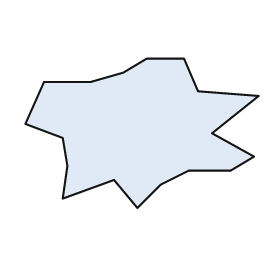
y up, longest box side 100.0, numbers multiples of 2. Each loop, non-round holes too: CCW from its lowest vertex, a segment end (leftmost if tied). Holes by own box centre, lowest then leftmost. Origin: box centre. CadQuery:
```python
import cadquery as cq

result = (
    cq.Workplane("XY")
    .moveTo(-2.0, -32.0)
    .lineTo(8.0, -22.0)
    .lineTo(20.0, -16.0)
    .lineTo(38.0, -16.0)
    .lineTo(48.0, -10.0)
    .lineTo(30.0, 0.0)
    .lineTo(50.0, 16.0)
    .lineTo(24.0, 18.0)
    .lineTo(18.0, 32.0)
    .lineTo(2.0, 32.0)
    .lineTo(-8.0, 26.0)
    .lineTo(-22.0, 22.0)
    .lineTo(-42.0, 22.0)
    .lineTo(-50.0, 4.0)
    .lineTo(-34.0, -2.0)
    .lineTo(-32.0, -14.0)
    .lineTo(-34.0, -28.0)
    .lineTo(-12.0, -20.0)
    .close()
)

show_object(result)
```